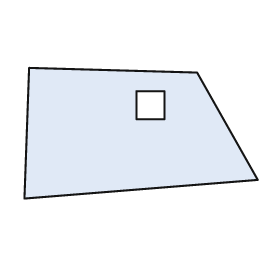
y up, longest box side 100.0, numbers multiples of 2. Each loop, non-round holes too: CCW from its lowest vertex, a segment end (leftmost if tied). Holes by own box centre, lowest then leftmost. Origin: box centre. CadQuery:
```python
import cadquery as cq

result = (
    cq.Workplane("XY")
    .moveTo(-50.0, -28.0)
    .lineTo(50.0, -20.0)
    .lineTo(24.0, 26.0)
    .lineTo(-48.0, 28.0)
    .close()
    .moveTo(-2.0, 6.0)
    .lineTo(10.0, 6.0)
    .lineTo(10.0, 18.0)
    .lineTo(-2.0, 18.0)
    .close()
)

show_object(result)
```